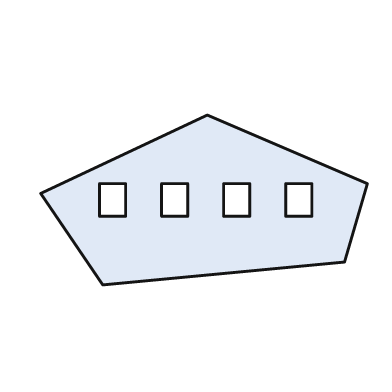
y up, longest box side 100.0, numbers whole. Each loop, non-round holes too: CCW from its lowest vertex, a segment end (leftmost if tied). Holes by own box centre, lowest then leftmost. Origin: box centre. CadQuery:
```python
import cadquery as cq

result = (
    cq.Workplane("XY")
    .moveTo(-31.0, -26.0)
    .lineTo(43.0, -19.0)
    .lineTo(50.0, 5.0)
    .lineTo(1.0, 26.0)
    .lineTo(-50.0, 2.0)
    .close()
    .moveTo(-32.0, -5.0)
    .lineTo(-24.0, -5.0)
    .lineTo(-24.0, 5.0)
    .lineTo(-32.0, 5.0)
    .close()
    .moveTo(-13.0, -5.0)
    .lineTo(-5.0, -5.0)
    .lineTo(-5.0, 5.0)
    .lineTo(-13.0, 5.0)
    .close()
    .moveTo(6.0, -5.0)
    .lineTo(14.0, -5.0)
    .lineTo(14.0, 5.0)
    .lineTo(6.0, 5.0)
    .close()
    .moveTo(25.0, -5.0)
    .lineTo(33.0, -5.0)
    .lineTo(33.0, 5.0)
    .lineTo(25.0, 5.0)
    .close()
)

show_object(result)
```